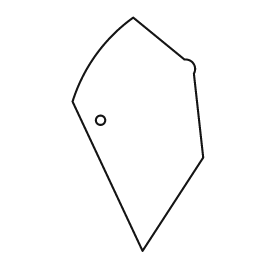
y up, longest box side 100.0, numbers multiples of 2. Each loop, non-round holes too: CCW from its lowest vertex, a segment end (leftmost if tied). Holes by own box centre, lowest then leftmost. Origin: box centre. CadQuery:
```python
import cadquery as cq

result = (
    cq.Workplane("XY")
    .moveTo(2.0, -50.0)
    .lineTo(28.0, -10.0)
    .lineTo(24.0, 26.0)
    .threePointArc((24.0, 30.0), (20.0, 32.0))
    .lineTo(-2.0, 50.0)
    .threePointArc((-18.0, 34.0), (-28.0, 14.0))
    .close()
    .moveTo(-16.0, 6.0)
    .circle(2.0)
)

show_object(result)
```